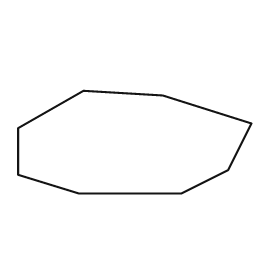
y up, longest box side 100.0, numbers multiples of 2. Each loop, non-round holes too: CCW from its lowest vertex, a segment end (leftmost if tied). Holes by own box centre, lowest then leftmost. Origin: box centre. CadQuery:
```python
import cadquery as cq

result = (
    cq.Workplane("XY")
    .moveTo(-24.0, -22.0)
    .lineTo(20.0, -22.0)
    .lineTo(40.0, -12.0)
    .lineTo(50.0, 8.0)
    .lineTo(12.0, 20.0)
    .lineTo(-22.0, 22.0)
    .lineTo(-50.0, 6.0)
    .lineTo(-50.0, -14.0)
    .close()
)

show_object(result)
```